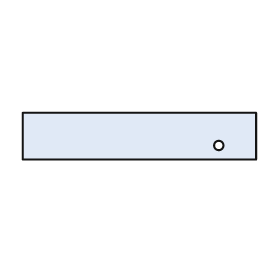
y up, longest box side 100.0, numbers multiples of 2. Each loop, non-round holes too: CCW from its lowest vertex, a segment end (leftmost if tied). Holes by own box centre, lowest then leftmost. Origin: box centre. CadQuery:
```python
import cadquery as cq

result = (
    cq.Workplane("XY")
    .moveTo(-50.0, -10.0)
    .lineTo(50.0, -10.0)
    .lineTo(50.0, 10.0)
    .lineTo(-50.0, 10.0)
    .close()
    .moveTo(34.0, -4.0)
    .circle(2.0)
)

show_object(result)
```